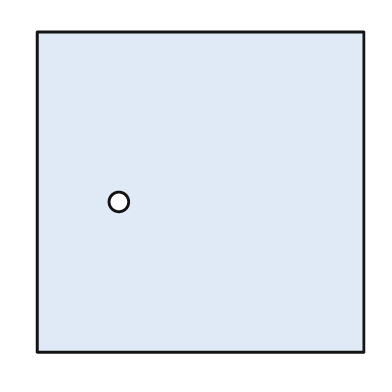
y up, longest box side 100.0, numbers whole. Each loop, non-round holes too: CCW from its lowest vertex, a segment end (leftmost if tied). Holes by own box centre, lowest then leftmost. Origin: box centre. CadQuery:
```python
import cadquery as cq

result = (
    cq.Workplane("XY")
    .moveTo(-50.0, -49.0)
    .lineTo(50.0, -49.0)
    .lineTo(50.0, 49.0)
    .lineTo(-50.0, 49.0)
    .close()
    .moveTo(-25.0, -3.0)
    .circle(3.0)
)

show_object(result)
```